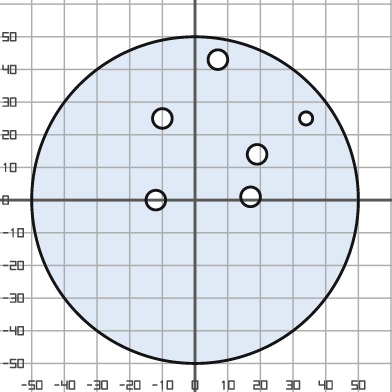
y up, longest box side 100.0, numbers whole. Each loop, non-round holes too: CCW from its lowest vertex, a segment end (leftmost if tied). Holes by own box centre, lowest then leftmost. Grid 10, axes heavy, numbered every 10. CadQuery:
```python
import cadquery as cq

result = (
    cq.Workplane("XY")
    .moveTo(0.0, 0.0)
    .circle(50.0)
    .moveTo(-12.0, 0.0)
    .circle(3.0)
    .moveTo(17.0, 1.0)
    .circle(3.0)
    .moveTo(19.0, 14.0)
    .circle(3.0)
    .moveTo(-10.0, 25.0)
    .circle(3.0)
    .moveTo(34.0, 25.0)
    .circle(2.0)
    .moveTo(7.0, 43.0)
    .circle(3.0)
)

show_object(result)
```